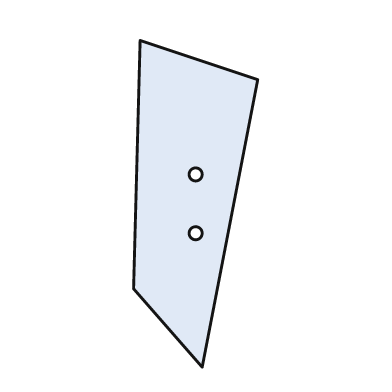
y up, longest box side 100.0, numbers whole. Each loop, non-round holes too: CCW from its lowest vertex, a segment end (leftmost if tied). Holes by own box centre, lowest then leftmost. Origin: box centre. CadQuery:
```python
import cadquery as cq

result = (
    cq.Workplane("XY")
    .moveTo(2.0, -50.0)
    .lineTo(19.0, 38.0)
    .lineTo(-17.0, 50.0)
    .lineTo(-19.0, -26.0)
    .close()
    .moveTo(0.0, -9.0)
    .circle(2.0)
    .moveTo(0.0, 9.0)
    .circle(2.0)
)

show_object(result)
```